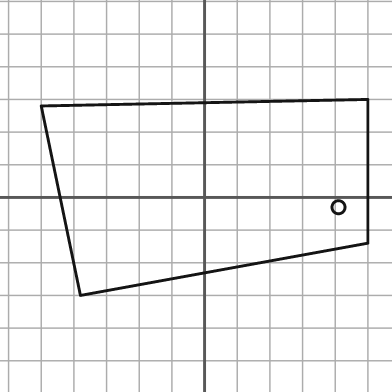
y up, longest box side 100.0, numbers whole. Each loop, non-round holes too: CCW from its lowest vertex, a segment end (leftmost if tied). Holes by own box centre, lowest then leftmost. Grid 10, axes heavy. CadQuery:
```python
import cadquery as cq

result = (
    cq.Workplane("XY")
    .moveTo(-38.0, -30.0)
    .lineTo(50.0, -14.0)
    .lineTo(50.0, 30.0)
    .lineTo(-50.0, 28.0)
    .close()
    .moveTo(41.0, -3.0)
    .circle(2.0)
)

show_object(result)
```